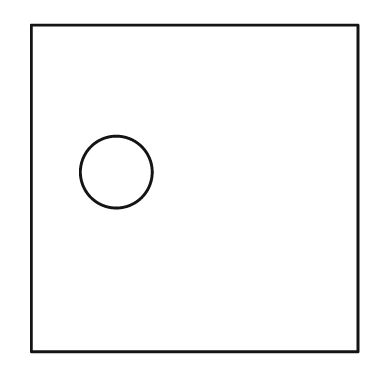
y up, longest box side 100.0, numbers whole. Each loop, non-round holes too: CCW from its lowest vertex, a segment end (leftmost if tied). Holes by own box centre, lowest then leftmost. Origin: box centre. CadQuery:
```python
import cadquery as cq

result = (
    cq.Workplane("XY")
    .moveTo(-50.0, -50.0)
    .lineTo(50.0, -50.0)
    .lineTo(50.0, 50.0)
    .lineTo(-50.0, 50.0)
    .close()
    .moveTo(-24.0, 5.0)
    .circle(11.0)
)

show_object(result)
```